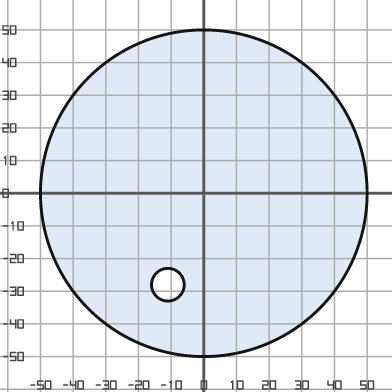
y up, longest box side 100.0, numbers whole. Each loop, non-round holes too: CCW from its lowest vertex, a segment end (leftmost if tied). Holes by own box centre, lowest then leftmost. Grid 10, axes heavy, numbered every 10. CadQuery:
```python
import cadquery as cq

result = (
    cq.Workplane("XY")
    .moveTo(0.0, 0.0)
    .circle(50.0)
    .moveTo(-11.0, -28.0)
    .circle(5.0)
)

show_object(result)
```